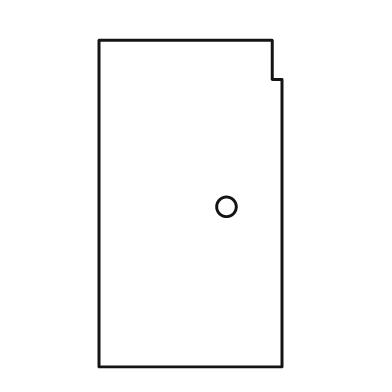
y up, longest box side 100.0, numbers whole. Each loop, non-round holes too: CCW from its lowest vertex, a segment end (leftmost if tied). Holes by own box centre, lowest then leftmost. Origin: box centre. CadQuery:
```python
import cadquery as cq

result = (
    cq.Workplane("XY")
    .moveTo(-28.0, -50.0)
    .lineTo(28.0, -50.0)
    .lineTo(28.0, 38.0)
    .lineTo(25.0, 38.0)
    .lineTo(25.0, 50.0)
    .lineTo(-28.0, 50.0)
    .close()
    .moveTo(11.0, -1.0)
    .circle(3.0)
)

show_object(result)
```